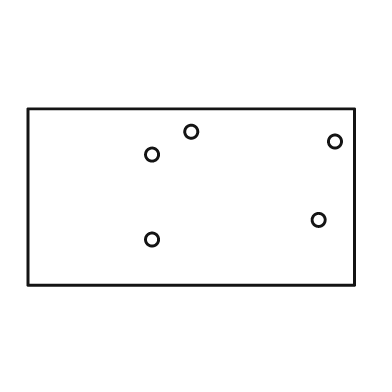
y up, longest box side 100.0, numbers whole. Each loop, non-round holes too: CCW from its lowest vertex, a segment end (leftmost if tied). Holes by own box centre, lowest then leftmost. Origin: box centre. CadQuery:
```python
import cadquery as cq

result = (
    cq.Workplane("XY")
    .moveTo(-50.0, -27.0)
    .lineTo(50.0, -27.0)
    .lineTo(50.0, 27.0)
    .lineTo(-50.0, 27.0)
    .close()
    .moveTo(-12.0, -13.0)
    .circle(2.0)
    .moveTo(39.0, -7.0)
    .circle(2.0)
    .moveTo(-12.0, 13.0)
    .circle(2.0)
    .moveTo(44.0, 17.0)
    .circle(2.0)
    .moveTo(0.0, 20.0)
    .circle(2.0)
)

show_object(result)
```